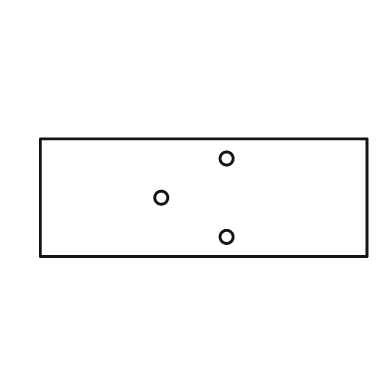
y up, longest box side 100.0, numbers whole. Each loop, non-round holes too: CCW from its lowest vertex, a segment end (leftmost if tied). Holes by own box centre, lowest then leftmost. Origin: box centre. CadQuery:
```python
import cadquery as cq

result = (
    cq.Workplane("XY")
    .moveTo(-50.0, -18.0)
    .lineTo(50.0, -18.0)
    .lineTo(50.0, 18.0)
    .lineTo(-50.0, 18.0)
    .close()
    .moveTo(7.0, -12.0)
    .circle(2.0)
    .moveTo(-13.0, 0.0)
    .circle(2.0)
    .moveTo(7.0, 12.0)
    .circle(2.0)
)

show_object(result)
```